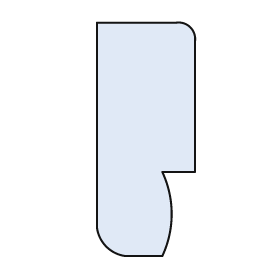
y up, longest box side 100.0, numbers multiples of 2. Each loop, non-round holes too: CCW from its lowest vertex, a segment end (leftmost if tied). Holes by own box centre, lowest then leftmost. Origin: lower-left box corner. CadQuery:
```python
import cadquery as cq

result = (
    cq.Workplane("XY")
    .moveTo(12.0, 0.0)
    .lineTo(28.0, 0.0)
    .threePointArc((32.0, 18.0), (28.0, 36.0))
    .lineTo(42.0, 36.0)
    .lineTo(42.0, 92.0)
    .threePointArc((40.0, 98.0), (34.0, 100.0))
    .lineTo(0.0, 100.0)
    .lineTo(0.0, 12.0)
    .threePointArc((4.0, 4.0), (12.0, 0.0))
    .close()
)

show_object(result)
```